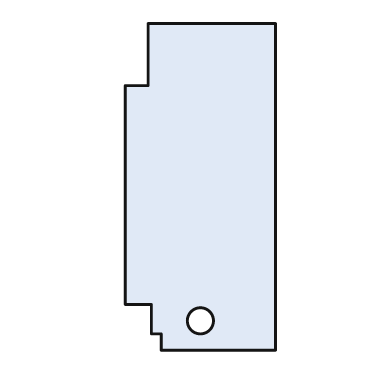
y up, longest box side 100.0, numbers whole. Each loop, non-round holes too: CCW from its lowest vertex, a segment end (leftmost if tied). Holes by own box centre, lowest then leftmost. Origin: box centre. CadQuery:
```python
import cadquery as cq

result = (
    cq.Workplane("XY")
    .moveTo(-12.0, -50.0)
    .lineTo(23.0, -50.0)
    .lineTo(23.0, 50.0)
    .lineTo(-16.0, 50.0)
    .lineTo(-16.0, 31.0)
    .lineTo(-23.0, 31.0)
    .lineTo(-23.0, -36.0)
    .lineTo(-15.0, -36.0)
    .lineTo(-15.0, -45.0)
    .lineTo(-12.0, -45.0)
    .close()
    .moveTo(0.0, -41.0)
    .circle(4.0)
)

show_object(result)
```